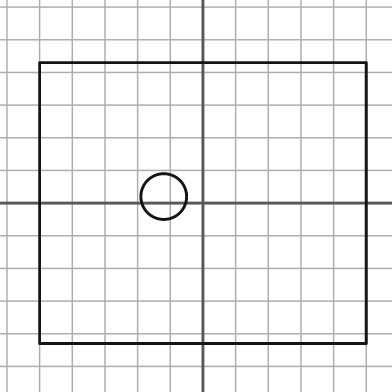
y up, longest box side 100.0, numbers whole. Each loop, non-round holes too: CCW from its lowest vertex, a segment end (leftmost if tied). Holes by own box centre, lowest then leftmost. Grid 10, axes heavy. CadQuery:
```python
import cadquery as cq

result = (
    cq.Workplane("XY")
    .moveTo(-50.0, -43.0)
    .lineTo(50.0, -43.0)
    .lineTo(50.0, 43.0)
    .lineTo(-50.0, 43.0)
    .close()
    .moveTo(-12.0, 2.0)
    .circle(7.0)
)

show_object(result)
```